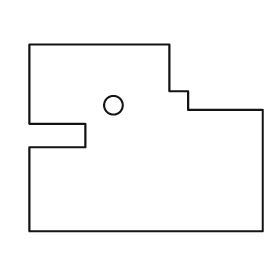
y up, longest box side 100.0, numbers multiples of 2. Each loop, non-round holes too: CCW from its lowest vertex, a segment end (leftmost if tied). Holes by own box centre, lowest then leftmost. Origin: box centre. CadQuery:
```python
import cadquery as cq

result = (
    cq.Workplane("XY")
    .moveTo(-50.0, -40.0)
    .lineTo(50.0, -40.0)
    .lineTo(50.0, 12.0)
    .lineTo(18.0, 12.0)
    .lineTo(18.0, 20.0)
    .lineTo(10.0, 20.0)
    .lineTo(10.0, 40.0)
    .lineTo(-50.0, 40.0)
    .lineTo(-50.0, 6.0)
    .lineTo(-26.0, 6.0)
    .lineTo(-26.0, -4.0)
    .lineTo(-50.0, -4.0)
    .close()
    .moveTo(-14.0, 14.0)
    .circle(4.0)
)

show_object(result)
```